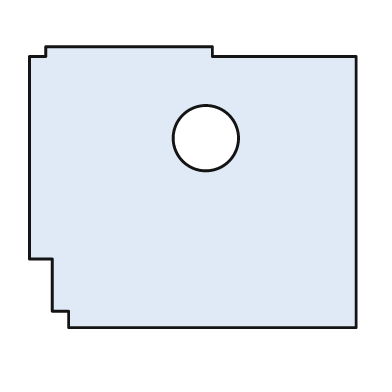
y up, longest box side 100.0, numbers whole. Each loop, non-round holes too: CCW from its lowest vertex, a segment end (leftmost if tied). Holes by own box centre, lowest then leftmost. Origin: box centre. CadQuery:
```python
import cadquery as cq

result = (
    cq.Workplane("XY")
    .moveTo(-38.0, -43.0)
    .lineTo(50.0, -43.0)
    .lineTo(50.0, 40.0)
    .lineTo(6.0, 40.0)
    .lineTo(6.0, 43.0)
    .lineTo(-45.0, 43.0)
    .lineTo(-45.0, 40.0)
    .lineTo(-50.0, 40.0)
    .lineTo(-50.0, -22.0)
    .lineTo(-43.0, -22.0)
    .lineTo(-43.0, -38.0)
    .lineTo(-38.0, -38.0)
    .close()
    .moveTo(4.0, 15.0)
    .circle(10.0)
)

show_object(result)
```